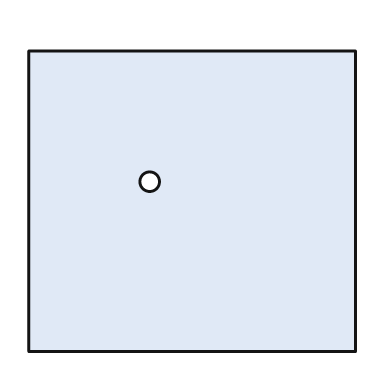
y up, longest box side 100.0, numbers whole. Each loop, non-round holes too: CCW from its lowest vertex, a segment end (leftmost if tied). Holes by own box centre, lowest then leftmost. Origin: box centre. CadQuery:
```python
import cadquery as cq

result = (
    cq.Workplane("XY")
    .moveTo(-50.0, -46.0)
    .lineTo(50.0, -46.0)
    .lineTo(50.0, 46.0)
    .lineTo(-50.0, 46.0)
    .close()
    .moveTo(-13.0, 6.0)
    .circle(3.0)
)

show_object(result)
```